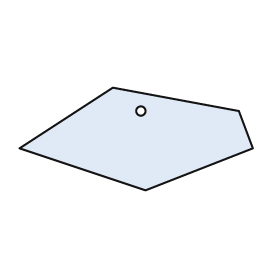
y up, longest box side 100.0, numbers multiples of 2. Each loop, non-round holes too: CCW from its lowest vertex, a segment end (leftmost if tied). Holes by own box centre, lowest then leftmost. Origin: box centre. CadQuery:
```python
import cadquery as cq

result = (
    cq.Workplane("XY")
    .moveTo(4.0, -22.0)
    .lineTo(50.0, -4.0)
    .lineTo(44.0, 12.0)
    .lineTo(-10.0, 22.0)
    .lineTo(-50.0, -4.0)
    .close()
    .moveTo(2.0, 12.0)
    .circle(2.0)
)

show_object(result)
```